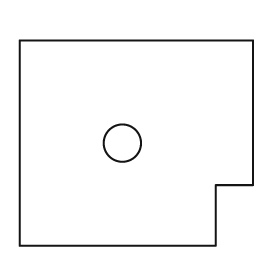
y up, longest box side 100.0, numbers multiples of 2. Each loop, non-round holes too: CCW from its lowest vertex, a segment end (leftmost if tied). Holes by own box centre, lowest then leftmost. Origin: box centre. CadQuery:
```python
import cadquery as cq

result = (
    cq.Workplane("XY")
    .moveTo(-50.0, -44.0)
    .lineTo(34.0, -44.0)
    .lineTo(34.0, -18.0)
    .lineTo(50.0, -18.0)
    .lineTo(50.0, 44.0)
    .lineTo(-50.0, 44.0)
    .close()
    .moveTo(-6.0, 0.0)
    .circle(8.0)
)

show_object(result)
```